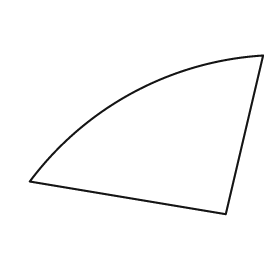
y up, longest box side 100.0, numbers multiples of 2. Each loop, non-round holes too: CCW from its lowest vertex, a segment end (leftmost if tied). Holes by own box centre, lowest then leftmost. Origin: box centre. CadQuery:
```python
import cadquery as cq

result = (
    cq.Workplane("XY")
    .moveTo(34.0, -34.0)
    .lineTo(50.0, 34.0)
    .threePointArc((-6.0, 18.0), (-50.0, -20.0))
    .close()
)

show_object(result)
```